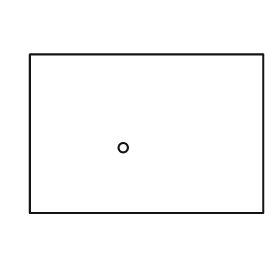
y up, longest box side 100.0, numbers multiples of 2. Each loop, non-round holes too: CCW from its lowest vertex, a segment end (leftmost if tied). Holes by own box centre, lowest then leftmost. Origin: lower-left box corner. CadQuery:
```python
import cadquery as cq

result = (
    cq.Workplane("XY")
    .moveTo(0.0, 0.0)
    .lineTo(100.0, 0.0)
    .lineTo(100.0, 68.0)
    .lineTo(0.0, 68.0)
    .close()
    .moveTo(40.0, 28.0)
    .circle(2.0)
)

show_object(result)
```